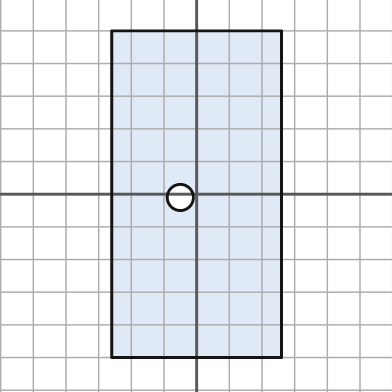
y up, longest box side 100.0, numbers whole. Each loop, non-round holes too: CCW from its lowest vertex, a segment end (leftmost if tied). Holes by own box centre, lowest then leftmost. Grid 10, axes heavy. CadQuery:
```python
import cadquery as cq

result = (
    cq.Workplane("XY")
    .moveTo(-26.0, -50.0)
    .lineTo(26.0, -50.0)
    .lineTo(26.0, 50.0)
    .lineTo(-26.0, 50.0)
    .close()
    .moveTo(-5.0, -1.0)
    .circle(4.0)
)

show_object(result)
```